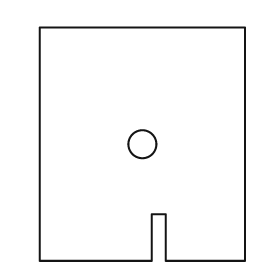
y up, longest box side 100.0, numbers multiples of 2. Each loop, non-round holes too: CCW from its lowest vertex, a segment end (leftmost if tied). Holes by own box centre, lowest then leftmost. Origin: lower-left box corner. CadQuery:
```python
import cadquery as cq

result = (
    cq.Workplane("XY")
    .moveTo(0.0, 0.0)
    .lineTo(48.0, 0.0)
    .lineTo(48.0, 20.0)
    .lineTo(54.0, 20.0)
    .lineTo(54.0, 0.0)
    .lineTo(88.0, 0.0)
    .lineTo(88.0, 100.0)
    .lineTo(0.0, 100.0)
    .close()
    .moveTo(44.0, 50.0)
    .circle(6.0)
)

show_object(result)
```